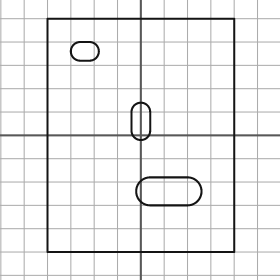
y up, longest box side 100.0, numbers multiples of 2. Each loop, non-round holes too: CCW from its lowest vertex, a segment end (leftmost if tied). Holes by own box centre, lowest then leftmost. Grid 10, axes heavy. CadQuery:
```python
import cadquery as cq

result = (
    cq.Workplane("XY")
    .moveTo(-40.0, -50.0)
    .lineTo(40.0, -50.0)
    .lineTo(40.0, 50.0)
    .lineTo(-40.0, 50.0)
    .close()
    .moveTo(4.0, -30.0)
    .lineTo(20.0, -30.0)
    .threePointArc((26.0, -24.0), (20.0, -18.0))
    .lineTo(4.0, -18.0)
    .threePointArc((-2.0, -24.0), (4.0, -30.0))
    .close()
    .moveTo(-4.0, 2.0)
    .threePointArc((0.0, -2.0), (4.0, 2.0))
    .lineTo(4.0, 10.0)
    .threePointArc((0.0, 14.0), (-4.0, 10.0))
    .close()
    .moveTo(-26.0, 32.0)
    .lineTo(-22.0, 32.0)
    .threePointArc((-18.0, 36.0), (-22.0, 40.0))
    .lineTo(-26.0, 40.0)
    .threePointArc((-30.0, 36.0), (-26.0, 32.0))
    .close()
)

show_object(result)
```